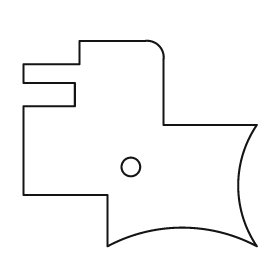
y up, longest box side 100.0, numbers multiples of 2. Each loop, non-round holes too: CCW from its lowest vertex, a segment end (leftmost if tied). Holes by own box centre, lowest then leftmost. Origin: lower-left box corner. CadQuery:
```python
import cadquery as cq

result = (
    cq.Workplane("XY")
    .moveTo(36.0, 0.0)
    .threePointArc((68.0, 8.0), (100.0, 0.0))
    .threePointArc((92.0, 26.0), (100.0, 52.0))
    .lineTo(60.0, 52.0)
    .lineTo(60.0, 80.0)
    .threePointArc((58.0, 86.0), (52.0, 88.0))
    .lineTo(24.0, 88.0)
    .lineTo(24.0, 78.0)
    .lineTo(0.0, 78.0)
    .lineTo(0.0, 70.0)
    .lineTo(22.0, 70.0)
    .lineTo(22.0, 60.0)
    .lineTo(0.0, 60.0)
    .lineTo(0.0, 22.0)
    .lineTo(36.0, 22.0)
    .close()
    .moveTo(46.0, 34.0)
    .circle(4.0)
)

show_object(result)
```